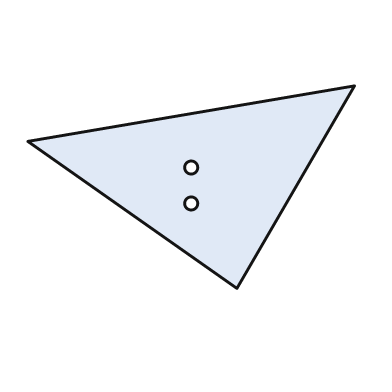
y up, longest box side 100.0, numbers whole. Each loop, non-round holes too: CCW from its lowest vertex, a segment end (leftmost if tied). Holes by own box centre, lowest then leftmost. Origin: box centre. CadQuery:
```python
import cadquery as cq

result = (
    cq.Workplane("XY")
    .moveTo(14.0, -31.0)
    .lineTo(50.0, 31.0)
    .lineTo(-50.0, 14.0)
    .close()
    .moveTo(0.0, -5.0)
    .circle(2.0)
    .moveTo(0.0, 6.0)
    .circle(2.0)
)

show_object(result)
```